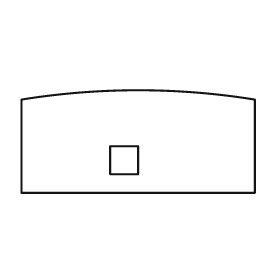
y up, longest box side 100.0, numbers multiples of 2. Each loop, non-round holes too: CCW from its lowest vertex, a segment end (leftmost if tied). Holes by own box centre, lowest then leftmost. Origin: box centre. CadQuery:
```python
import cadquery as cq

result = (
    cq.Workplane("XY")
    .moveTo(-50.0, -22.0)
    .lineTo(50.0, -22.0)
    .lineTo(50.0, 18.0)
    .threePointArc((0.0, 22.0), (-50.0, 18.0))
    .close()
    .moveTo(-12.0, -14.0)
    .lineTo(0.0, -14.0)
    .lineTo(0.0, -2.0)
    .lineTo(-12.0, -2.0)
    .close()
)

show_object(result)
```